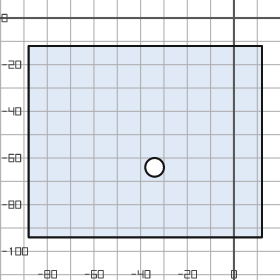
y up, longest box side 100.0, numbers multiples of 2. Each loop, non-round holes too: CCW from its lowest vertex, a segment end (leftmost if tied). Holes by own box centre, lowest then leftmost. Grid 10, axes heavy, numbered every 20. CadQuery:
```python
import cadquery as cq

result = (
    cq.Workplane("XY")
    .moveTo(-88.0, -94.0)
    .lineTo(12.0, -94.0)
    .lineTo(12.0, -12.0)
    .lineTo(-88.0, -12.0)
    .close()
    .moveTo(-34.0, -64.0)
    .circle(4.0)
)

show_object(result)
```